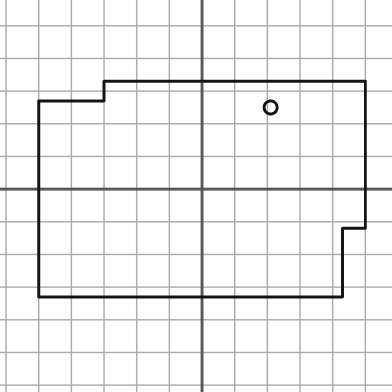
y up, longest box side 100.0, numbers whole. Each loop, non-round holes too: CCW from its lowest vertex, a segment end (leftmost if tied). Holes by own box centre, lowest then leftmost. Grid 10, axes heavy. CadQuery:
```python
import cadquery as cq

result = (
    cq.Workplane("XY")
    .moveTo(-50.0, -33.0)
    .lineTo(43.0, -33.0)
    .lineTo(43.0, -12.0)
    .lineTo(50.0, -12.0)
    .lineTo(50.0, 33.0)
    .lineTo(-30.0, 33.0)
    .lineTo(-30.0, 27.0)
    .lineTo(-50.0, 27.0)
    .close()
    .moveTo(21.0, 25.0)
    .circle(2.0)
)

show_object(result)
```